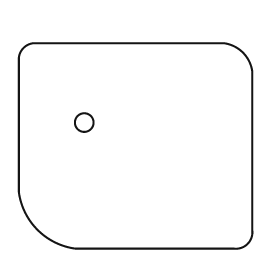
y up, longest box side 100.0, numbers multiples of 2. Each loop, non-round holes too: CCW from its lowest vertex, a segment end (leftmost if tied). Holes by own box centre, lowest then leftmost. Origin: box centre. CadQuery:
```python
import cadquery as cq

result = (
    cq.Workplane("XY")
    .moveTo(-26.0, -44.0)
    .lineTo(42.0, -44.0)
    .threePointArc((48.0, -42.0), (50.0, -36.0))
    .lineTo(50.0, 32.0)
    .threePointArc((46.0, 40.0), (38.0, 44.0))
    .lineTo(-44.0, 44.0)
    .threePointArc((-48.0, 42.0), (-50.0, 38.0))
    .lineTo(-50.0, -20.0)
    .threePointArc((-42.0, -36.0), (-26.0, -44.0))
    .close()
    .moveTo(-22.0, 10.0)
    .circle(4.0)
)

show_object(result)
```